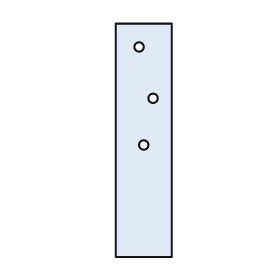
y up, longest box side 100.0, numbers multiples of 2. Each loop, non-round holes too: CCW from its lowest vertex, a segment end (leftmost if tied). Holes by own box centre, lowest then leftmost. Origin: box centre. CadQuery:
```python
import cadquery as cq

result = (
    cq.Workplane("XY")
    .moveTo(-12.0, -50.0)
    .lineTo(12.0, -50.0)
    .lineTo(12.0, 50.0)
    .lineTo(-12.0, 50.0)
    .close()
    .moveTo(0.0, -2.0)
    .circle(2.0)
    .moveTo(4.0, 18.0)
    .circle(2.0)
    .moveTo(-2.0, 40.0)
    .circle(2.0)
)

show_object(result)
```